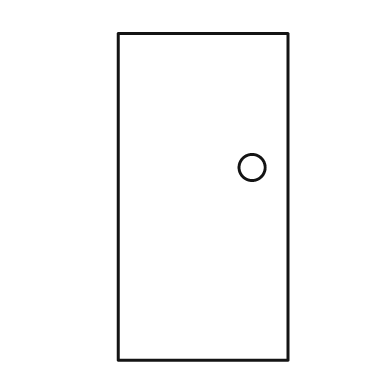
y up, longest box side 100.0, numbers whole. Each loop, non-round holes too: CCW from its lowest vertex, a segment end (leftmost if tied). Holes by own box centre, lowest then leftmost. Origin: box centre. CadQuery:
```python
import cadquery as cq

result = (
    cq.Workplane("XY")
    .moveTo(-26.0, -50.0)
    .lineTo(26.0, -50.0)
    .lineTo(26.0, 50.0)
    .lineTo(-26.0, 50.0)
    .close()
    .moveTo(15.0, 9.0)
    .circle(4.0)
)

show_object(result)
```